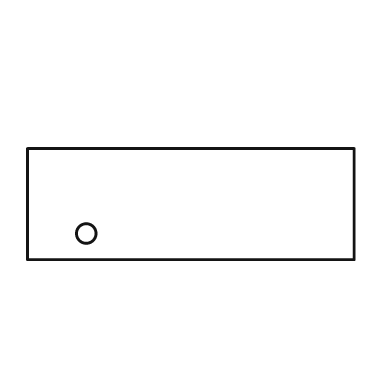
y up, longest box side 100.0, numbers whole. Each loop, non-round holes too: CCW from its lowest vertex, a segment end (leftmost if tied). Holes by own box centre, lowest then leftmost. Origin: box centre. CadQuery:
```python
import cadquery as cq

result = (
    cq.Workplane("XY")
    .moveTo(-50.0, -17.0)
    .lineTo(50.0, -17.0)
    .lineTo(50.0, 17.0)
    .lineTo(-50.0, 17.0)
    .close()
    .moveTo(-32.0, -9.0)
    .circle(3.0)
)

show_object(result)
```